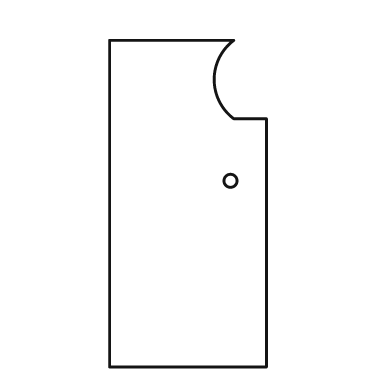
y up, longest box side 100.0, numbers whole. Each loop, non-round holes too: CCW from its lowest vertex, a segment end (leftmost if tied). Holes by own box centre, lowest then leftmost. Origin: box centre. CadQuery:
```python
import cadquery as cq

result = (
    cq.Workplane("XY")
    .moveTo(-24.0, -50.0)
    .lineTo(24.0, -50.0)
    .lineTo(24.0, 26.0)
    .lineTo(14.0, 26.0)
    .threePointArc((8.0, 38.0), (14.0, 50.0))
    .lineTo(-24.0, 50.0)
    .close()
    .moveTo(13.0, 7.0)
    .circle(2.0)
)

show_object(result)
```